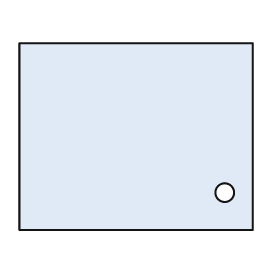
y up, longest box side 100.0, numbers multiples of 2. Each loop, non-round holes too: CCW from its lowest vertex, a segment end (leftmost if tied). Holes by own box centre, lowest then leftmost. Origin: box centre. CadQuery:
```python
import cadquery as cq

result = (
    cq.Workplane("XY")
    .moveTo(-50.0, -40.0)
    .lineTo(50.0, -40.0)
    .lineTo(50.0, 40.0)
    .lineTo(-50.0, 40.0)
    .close()
    .moveTo(38.0, -24.0)
    .circle(4.0)
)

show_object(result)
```